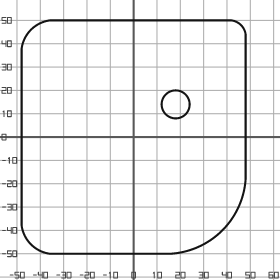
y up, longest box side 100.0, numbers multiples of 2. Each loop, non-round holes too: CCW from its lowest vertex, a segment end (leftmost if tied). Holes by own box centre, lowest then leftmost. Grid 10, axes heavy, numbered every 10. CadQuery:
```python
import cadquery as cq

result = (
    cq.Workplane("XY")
    .moveTo(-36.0, -50.0)
    .lineTo(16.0, -50.0)
    .threePointArc((38.0, -40.0), (48.0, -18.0))
    .lineTo(48.0, 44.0)
    .threePointArc((46.0, 48.0), (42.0, 50.0))
    .lineTo(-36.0, 50.0)
    .threePointArc((-44.0, 46.0), (-48.0, 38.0))
    .lineTo(-48.0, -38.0)
    .threePointArc((-44.0, -46.0), (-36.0, -50.0))
    .close()
    .moveTo(18.0, 14.0)
    .circle(6.0)
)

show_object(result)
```